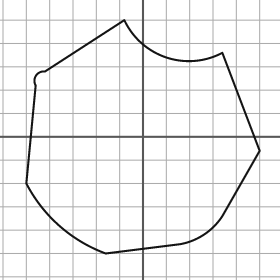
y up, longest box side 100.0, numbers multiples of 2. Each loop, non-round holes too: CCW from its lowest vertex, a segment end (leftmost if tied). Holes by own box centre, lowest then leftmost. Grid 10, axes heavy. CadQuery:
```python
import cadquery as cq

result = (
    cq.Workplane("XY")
    .moveTo(-16.0, -50.0)
    .lineTo(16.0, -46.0)
    .threePointArc((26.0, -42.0), (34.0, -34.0))
    .lineTo(50.0, -6.0)
    .lineTo(34.0, 36.0)
    .threePointArc((10.0, 34.0), (-8.0, 50.0))
    .lineTo(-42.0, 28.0)
    .threePointArc((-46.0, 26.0), (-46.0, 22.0))
    .lineTo(-50.0, -20.0)
    .threePointArc((-36.0, -38.0), (-16.0, -50.0))
    .close()
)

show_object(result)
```